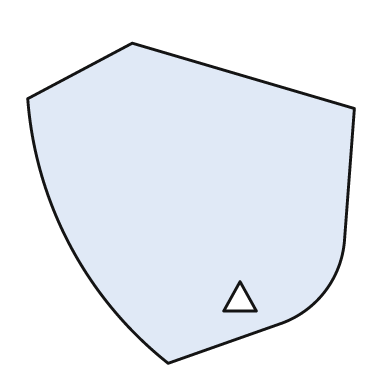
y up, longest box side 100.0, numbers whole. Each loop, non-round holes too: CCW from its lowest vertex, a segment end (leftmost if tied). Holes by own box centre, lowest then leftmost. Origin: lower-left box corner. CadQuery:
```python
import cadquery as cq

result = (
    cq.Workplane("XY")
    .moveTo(43.0, 0.0)
    .lineTo(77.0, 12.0)
    .threePointArc((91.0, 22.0), (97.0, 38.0))
    .lineTo(100.0, 78.0)
    .lineTo(32.0, 98.0)
    .lineTo(0.0, 81.0)
    .threePointArc((13.0, 36.0), (43.0, 0.0))
    .close()
    .moveTo(60.0, 16.0)
    .lineTo(70.0, 16.0)
    .lineTo(65.0, 25.0)
    .close()
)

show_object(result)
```